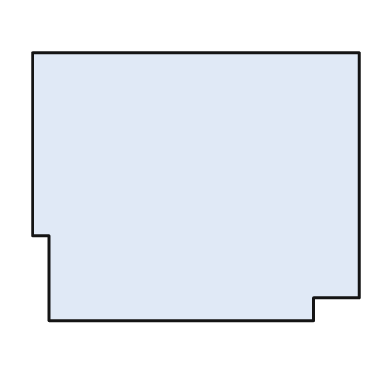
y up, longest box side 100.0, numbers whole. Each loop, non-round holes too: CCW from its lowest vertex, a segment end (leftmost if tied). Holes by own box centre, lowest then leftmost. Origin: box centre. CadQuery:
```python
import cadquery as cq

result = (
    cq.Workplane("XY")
    .moveTo(-45.0, -41.0)
    .lineTo(36.0, -41.0)
    .lineTo(36.0, -34.0)
    .lineTo(50.0, -34.0)
    .lineTo(50.0, 41.0)
    .lineTo(-50.0, 41.0)
    .lineTo(-50.0, -15.0)
    .lineTo(-45.0, -15.0)
    .close()
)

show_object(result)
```